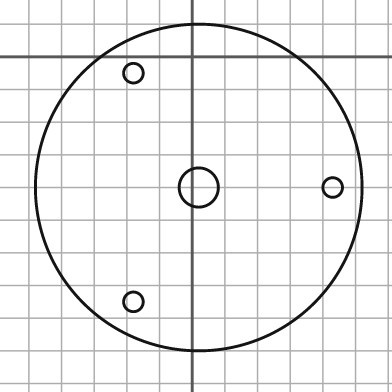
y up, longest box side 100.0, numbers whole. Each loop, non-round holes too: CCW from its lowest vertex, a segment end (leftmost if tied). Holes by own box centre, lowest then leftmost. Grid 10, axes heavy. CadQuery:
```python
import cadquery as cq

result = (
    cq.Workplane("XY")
    .moveTo(2.0, -40.0)
    .circle(50.0)
    .moveTo(-18.0, -75.0)
    .circle(3.0)
    .moveTo(2.0, -40.0)
    .circle(6.0)
    .moveTo(43.0, -40.0)
    .circle(3.0)
    .moveTo(-18.0, -5.0)
    .circle(3.0)
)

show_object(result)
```